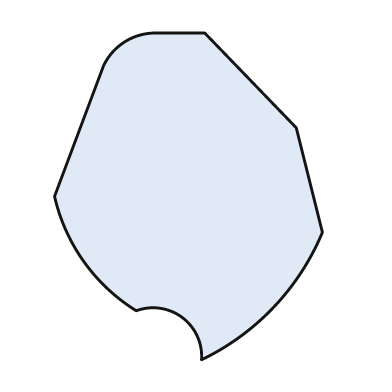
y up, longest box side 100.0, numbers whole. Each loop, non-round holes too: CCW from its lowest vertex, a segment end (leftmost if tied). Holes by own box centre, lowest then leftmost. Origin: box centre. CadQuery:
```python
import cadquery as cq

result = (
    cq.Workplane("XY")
    .moveTo(4.0, -50.0)
    .threePointArc((26.0, -34.0), (41.0, -11.0))
    .lineTo(33.0, 21.0)
    .lineTo(5.0, 50.0)
    .lineTo(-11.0, 50.0)
    .threePointArc((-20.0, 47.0), (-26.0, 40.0))
    .lineTo(-41.0, 0.0)
    .threePointArc((-32.0, -20.0), (-16.0, -35.0))
    .threePointArc((-2.0, -37.0), (4.0, -50.0))
    .close()
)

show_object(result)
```